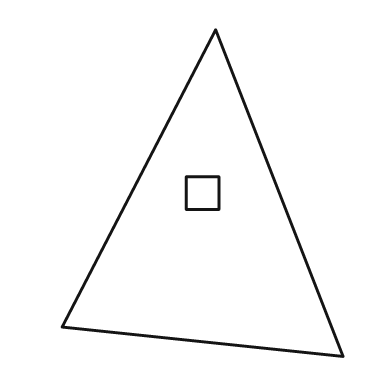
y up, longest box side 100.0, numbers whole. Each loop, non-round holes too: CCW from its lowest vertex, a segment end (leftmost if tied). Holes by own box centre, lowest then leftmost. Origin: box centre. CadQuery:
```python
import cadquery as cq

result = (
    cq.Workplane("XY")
    .moveTo(43.0, -50.0)
    .lineTo(4.0, 50.0)
    .lineTo(-43.0, -41.0)
    .close()
    .moveTo(-5.0, -5.0)
    .lineTo(5.0, -5.0)
    .lineTo(5.0, 5.0)
    .lineTo(-5.0, 5.0)
    .close()
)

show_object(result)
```